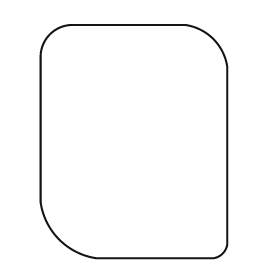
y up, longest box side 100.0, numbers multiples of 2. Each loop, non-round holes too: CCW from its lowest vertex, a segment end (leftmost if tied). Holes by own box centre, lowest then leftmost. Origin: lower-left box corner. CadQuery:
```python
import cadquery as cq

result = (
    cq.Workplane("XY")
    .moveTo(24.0, 0.0)
    .lineTo(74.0, 0.0)
    .threePointArc((78.0, 2.0), (80.0, 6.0))
    .lineTo(80.0, 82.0)
    .threePointArc((74.0, 94.0), (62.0, 100.0))
    .lineTo(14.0, 100.0)
    .threePointArc((4.0, 96.0), (0.0, 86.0))
    .lineTo(0.0, 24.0)
    .threePointArc((8.0, 8.0), (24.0, 0.0))
    .close()
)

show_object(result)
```